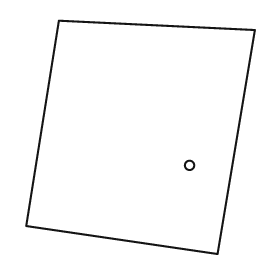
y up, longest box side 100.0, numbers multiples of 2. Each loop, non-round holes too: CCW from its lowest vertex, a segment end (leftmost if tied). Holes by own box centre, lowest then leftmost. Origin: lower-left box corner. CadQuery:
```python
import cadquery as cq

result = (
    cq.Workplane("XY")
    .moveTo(82.0, 0.0)
    .lineTo(98.0, 96.0)
    .lineTo(14.0, 100.0)
    .lineTo(0.0, 12.0)
    .close()
    .moveTo(70.0, 38.0)
    .circle(2.0)
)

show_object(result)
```